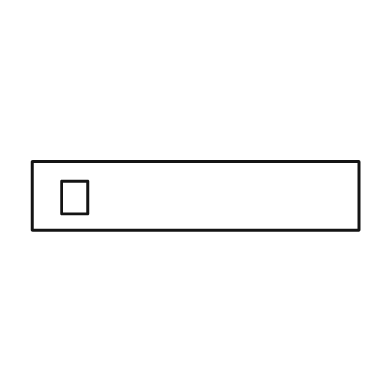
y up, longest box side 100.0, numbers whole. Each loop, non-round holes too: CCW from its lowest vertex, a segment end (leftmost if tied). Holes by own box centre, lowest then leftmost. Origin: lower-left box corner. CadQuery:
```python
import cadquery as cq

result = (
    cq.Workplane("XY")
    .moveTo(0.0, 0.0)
    .lineTo(100.0, 0.0)
    .lineTo(100.0, 21.0)
    .lineTo(0.0, 21.0)
    .close()
    .moveTo(9.0, 5.0)
    .lineTo(17.0, 5.0)
    .lineTo(17.0, 15.0)
    .lineTo(9.0, 15.0)
    .close()
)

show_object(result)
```